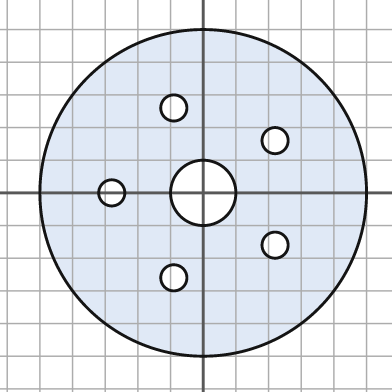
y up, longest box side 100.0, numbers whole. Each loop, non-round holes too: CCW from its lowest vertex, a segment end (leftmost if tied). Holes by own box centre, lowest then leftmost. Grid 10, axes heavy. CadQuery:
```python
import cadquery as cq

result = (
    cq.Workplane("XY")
    .moveTo(0.0, 0.0)
    .circle(50.0)
    .moveTo(-9.0, -26.0)
    .circle(4.0)
    .moveTo(22.0, -16.0)
    .circle(4.0)
    .moveTo(-28.0, 0.0)
    .circle(4.0)
    .moveTo(0.0, 0.0)
    .circle(10.0)
    .moveTo(22.0, 16.0)
    .circle(4.0)
    .moveTo(-9.0, 26.0)
    .circle(4.0)
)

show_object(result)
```